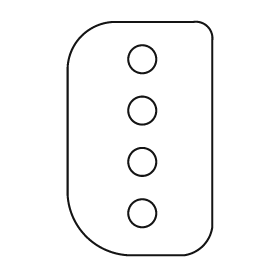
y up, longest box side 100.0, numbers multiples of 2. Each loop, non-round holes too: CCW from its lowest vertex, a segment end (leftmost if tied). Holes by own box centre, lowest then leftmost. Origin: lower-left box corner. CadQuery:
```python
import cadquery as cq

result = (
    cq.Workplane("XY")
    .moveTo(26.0, 0.0)
    .lineTo(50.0, 0.0)
    .threePointArc((58.0, 4.0), (62.0, 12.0))
    .lineTo(62.0, 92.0)
    .threePointArc((60.0, 98.0), (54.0, 100.0))
    .lineTo(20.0, 100.0)
    .threePointArc((6.0, 94.0), (0.0, 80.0))
    .lineTo(0.0, 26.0)
    .threePointArc((8.0, 8.0), (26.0, 0.0))
    .close()
    .moveTo(32.0, 18.0)
    .circle(6.0)
    .moveTo(32.0, 40.0)
    .circle(6.0)
    .moveTo(32.0, 62.0)
    .circle(6.0)
    .moveTo(32.0, 84.0)
    .circle(6.0)
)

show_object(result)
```